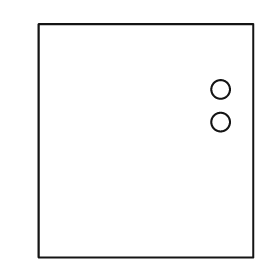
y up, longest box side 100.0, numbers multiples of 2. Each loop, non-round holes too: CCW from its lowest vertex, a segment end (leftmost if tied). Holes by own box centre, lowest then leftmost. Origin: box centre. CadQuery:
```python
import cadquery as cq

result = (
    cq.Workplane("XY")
    .moveTo(-46.0, -50.0)
    .lineTo(46.0, -50.0)
    .lineTo(46.0, 50.0)
    .lineTo(-46.0, 50.0)
    .close()
    .moveTo(32.0, 8.0)
    .circle(4.0)
    .moveTo(32.0, 22.0)
    .circle(4.0)
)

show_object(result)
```